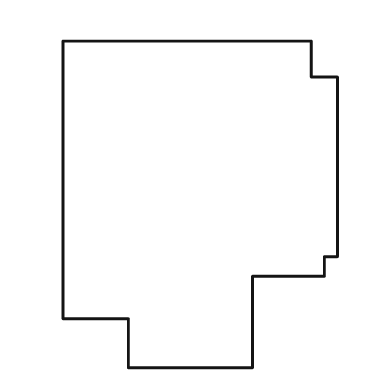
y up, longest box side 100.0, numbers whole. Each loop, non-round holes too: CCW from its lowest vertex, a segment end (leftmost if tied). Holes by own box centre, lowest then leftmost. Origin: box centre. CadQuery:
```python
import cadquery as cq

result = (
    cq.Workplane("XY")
    .moveTo(-22.0, -50.0)
    .lineTo(16.0, -50.0)
    .lineTo(16.0, -22.0)
    .lineTo(38.0, -22.0)
    .lineTo(38.0, -16.0)
    .lineTo(42.0, -16.0)
    .lineTo(42.0, 39.0)
    .lineTo(34.0, 39.0)
    .lineTo(34.0, 50.0)
    .lineTo(-42.0, 50.0)
    .lineTo(-42.0, -35.0)
    .lineTo(-22.0, -35.0)
    .close()
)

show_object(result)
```